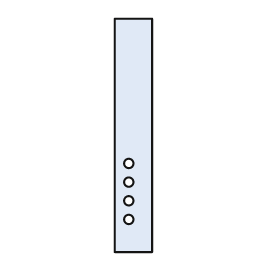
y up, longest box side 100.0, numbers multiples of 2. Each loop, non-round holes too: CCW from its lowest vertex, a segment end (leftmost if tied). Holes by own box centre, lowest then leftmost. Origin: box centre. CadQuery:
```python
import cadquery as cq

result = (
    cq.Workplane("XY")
    .moveTo(-8.0, -50.0)
    .lineTo(8.0, -50.0)
    .lineTo(8.0, 50.0)
    .lineTo(-8.0, 50.0)
    .close()
    .moveTo(-2.0, -36.0)
    .circle(2.0)
    .moveTo(-2.0, -28.0)
    .circle(2.0)
    .moveTo(-2.0, -20.0)
    .circle(2.0)
    .moveTo(-2.0, -12.0)
    .circle(2.0)
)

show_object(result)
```